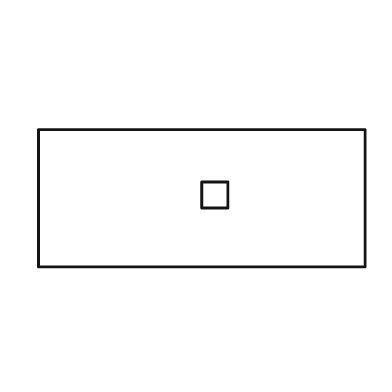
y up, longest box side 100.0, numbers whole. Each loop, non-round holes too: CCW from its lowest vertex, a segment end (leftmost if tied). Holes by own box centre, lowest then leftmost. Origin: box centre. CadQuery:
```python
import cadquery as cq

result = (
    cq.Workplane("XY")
    .moveTo(-50.0, -21.0)
    .lineTo(50.0, -21.0)
    .lineTo(50.0, 21.0)
    .lineTo(-50.0, 21.0)
    .close()
    .moveTo(0.0, -3.0)
    .lineTo(8.0, -3.0)
    .lineTo(8.0, 5.0)
    .lineTo(0.0, 5.0)
    .close()
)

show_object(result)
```